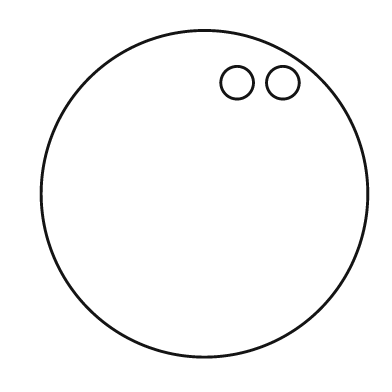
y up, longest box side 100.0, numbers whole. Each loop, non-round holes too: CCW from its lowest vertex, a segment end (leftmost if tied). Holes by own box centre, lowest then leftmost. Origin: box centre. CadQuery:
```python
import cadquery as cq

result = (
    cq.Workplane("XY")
    .moveTo(0.0, 0.0)
    .circle(50.0)
    .moveTo(10.0, 34.0)
    .circle(5.0)
    .moveTo(24.0, 34.0)
    .circle(5.0)
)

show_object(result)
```